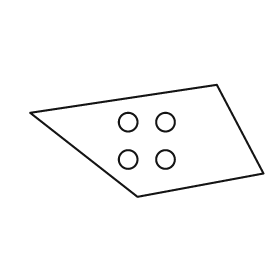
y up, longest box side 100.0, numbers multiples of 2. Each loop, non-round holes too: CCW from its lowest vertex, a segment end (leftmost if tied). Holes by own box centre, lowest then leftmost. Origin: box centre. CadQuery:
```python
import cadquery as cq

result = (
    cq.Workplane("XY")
    .moveTo(-4.0, -24.0)
    .lineTo(50.0, -14.0)
    .lineTo(30.0, 24.0)
    .lineTo(-50.0, 12.0)
    .close()
    .moveTo(-8.0, -8.0)
    .circle(4.0)
    .moveTo(8.0, -8.0)
    .circle(4.0)
    .moveTo(-8.0, 8.0)
    .circle(4.0)
    .moveTo(8.0, 8.0)
    .circle(4.0)
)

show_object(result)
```